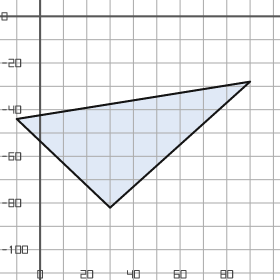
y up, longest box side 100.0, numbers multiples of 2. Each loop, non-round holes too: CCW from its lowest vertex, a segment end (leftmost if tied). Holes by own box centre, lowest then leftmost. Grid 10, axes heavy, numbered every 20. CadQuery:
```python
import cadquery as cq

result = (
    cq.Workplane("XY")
    .moveTo(30.0, -82.0)
    .lineTo(90.0, -28.0)
    .lineTo(-10.0, -44.0)
    .close()
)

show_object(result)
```